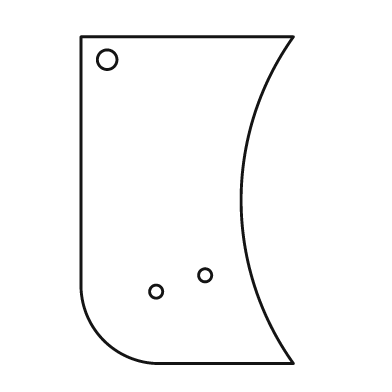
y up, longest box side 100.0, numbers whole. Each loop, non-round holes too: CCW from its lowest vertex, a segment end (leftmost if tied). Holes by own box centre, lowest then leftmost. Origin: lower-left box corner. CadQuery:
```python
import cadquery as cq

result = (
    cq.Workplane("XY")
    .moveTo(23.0, 0.0)
    .lineTo(65.0, 0.0)
    .threePointArc((49.0, 50.0), (65.0, 100.0))
    .lineTo(0.0, 100.0)
    .lineTo(0.0, 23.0)
    .threePointArc((7.0, 7.0), (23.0, 0.0))
    .close()
    .moveTo(23.0, 22.0)
    .circle(2.0)
    .moveTo(38.0, 27.0)
    .circle(2.0)
    .moveTo(8.0, 93.0)
    .circle(3.0)
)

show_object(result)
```